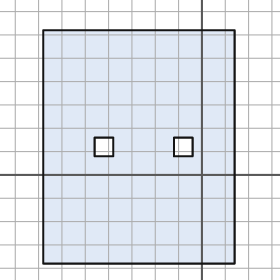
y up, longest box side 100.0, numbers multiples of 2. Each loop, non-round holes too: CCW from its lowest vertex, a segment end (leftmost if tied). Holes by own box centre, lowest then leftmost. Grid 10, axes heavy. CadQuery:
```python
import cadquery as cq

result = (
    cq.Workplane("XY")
    .moveTo(-68.0, -38.0)
    .lineTo(14.0, -38.0)
    .lineTo(14.0, 62.0)
    .lineTo(-68.0, 62.0)
    .close()
    .moveTo(-46.0, 8.0)
    .lineTo(-38.0, 8.0)
    .lineTo(-38.0, 16.0)
    .lineTo(-46.0, 16.0)
    .close()
    .moveTo(-12.0, 8.0)
    .lineTo(-4.0, 8.0)
    .lineTo(-4.0, 16.0)
    .lineTo(-12.0, 16.0)
    .close()
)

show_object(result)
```